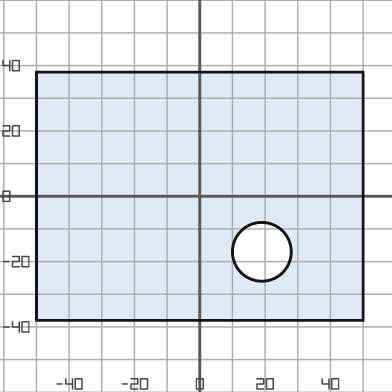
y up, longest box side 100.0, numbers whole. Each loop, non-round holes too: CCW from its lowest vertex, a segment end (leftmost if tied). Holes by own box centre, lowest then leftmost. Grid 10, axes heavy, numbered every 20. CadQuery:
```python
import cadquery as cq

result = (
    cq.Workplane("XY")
    .moveTo(-50.0, -38.0)
    .lineTo(50.0, -38.0)
    .lineTo(50.0, 38.0)
    .lineTo(-50.0, 38.0)
    .close()
    .moveTo(19.0, -17.0)
    .circle(9.0)
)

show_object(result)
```